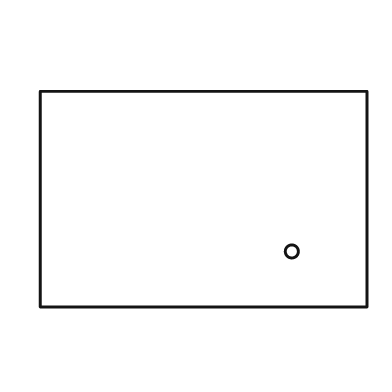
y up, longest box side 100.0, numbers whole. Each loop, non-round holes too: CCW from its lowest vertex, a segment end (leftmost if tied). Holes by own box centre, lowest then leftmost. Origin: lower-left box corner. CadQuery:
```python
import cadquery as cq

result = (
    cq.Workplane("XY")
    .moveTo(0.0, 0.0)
    .lineTo(100.0, 0.0)
    .lineTo(100.0, 66.0)
    .lineTo(0.0, 66.0)
    .close()
    .moveTo(77.0, 17.0)
    .circle(2.0)
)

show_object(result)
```